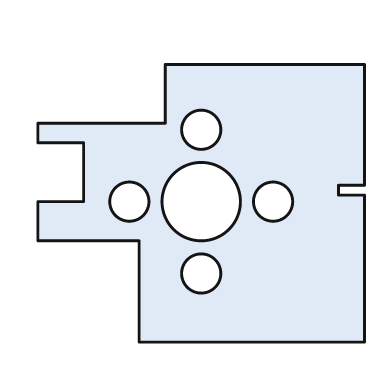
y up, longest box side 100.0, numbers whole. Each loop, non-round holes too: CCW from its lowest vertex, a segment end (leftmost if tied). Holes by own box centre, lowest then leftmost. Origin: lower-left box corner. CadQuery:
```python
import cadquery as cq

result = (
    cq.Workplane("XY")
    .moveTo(31.0, 0.0)
    .lineTo(100.0, 0.0)
    .lineTo(100.0, 45.0)
    .lineTo(92.0, 45.0)
    .lineTo(92.0, 48.0)
    .lineTo(100.0, 48.0)
    .lineTo(100.0, 85.0)
    .lineTo(39.0, 85.0)
    .lineTo(39.0, 67.0)
    .lineTo(0.0, 67.0)
    .lineTo(0.0, 61.0)
    .lineTo(14.0, 61.0)
    .lineTo(14.0, 43.0)
    .lineTo(0.0, 43.0)
    .lineTo(0.0, 31.0)
    .lineTo(31.0, 31.0)
    .close()
    .moveTo(50.0, 21.0)
    .circle(6.0)
    .moveTo(28.0, 43.0)
    .circle(6.0)
    .moveTo(50.0, 43.0)
    .circle(12.0)
    .moveTo(72.0, 43.0)
    .circle(6.0)
    .moveTo(50.0, 65.0)
    .circle(6.0)
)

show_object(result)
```